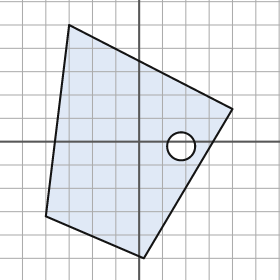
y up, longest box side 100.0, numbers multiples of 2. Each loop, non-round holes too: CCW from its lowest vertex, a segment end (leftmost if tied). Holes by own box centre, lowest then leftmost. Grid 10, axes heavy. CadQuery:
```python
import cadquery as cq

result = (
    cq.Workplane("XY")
    .moveTo(2.0, -50.0)
    .lineTo(40.0, 14.0)
    .lineTo(-30.0, 50.0)
    .lineTo(-40.0, -32.0)
    .close()
    .moveTo(18.0, -2.0)
    .circle(6.0)
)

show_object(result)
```